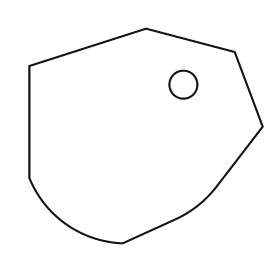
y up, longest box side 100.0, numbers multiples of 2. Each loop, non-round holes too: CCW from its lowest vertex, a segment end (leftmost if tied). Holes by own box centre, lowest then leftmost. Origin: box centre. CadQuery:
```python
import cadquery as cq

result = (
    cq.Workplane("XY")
    .moveTo(-10.0, -46.0)
    .lineTo(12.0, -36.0)
    .threePointArc((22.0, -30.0), (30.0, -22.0))
    .lineTo(50.0, 4.0)
    .lineTo(38.0, 36.0)
    .lineTo(0.0, 46.0)
    .lineTo(-50.0, 30.0)
    .lineTo(-50.0, -18.0)
    .threePointArc((-34.0, -38.0), (-10.0, -46.0))
    .close()
    .moveTo(16.0, 22.0)
    .circle(6.0)
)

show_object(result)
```